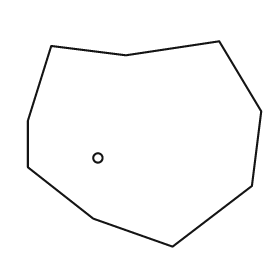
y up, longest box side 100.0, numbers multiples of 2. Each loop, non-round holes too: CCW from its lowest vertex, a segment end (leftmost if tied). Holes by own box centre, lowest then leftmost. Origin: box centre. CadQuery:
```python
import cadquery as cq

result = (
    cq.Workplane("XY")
    .moveTo(12.0, -44.0)
    .lineTo(46.0, -18.0)
    .lineTo(50.0, 14.0)
    .lineTo(32.0, 44.0)
    .lineTo(-8.0, 38.0)
    .lineTo(-40.0, 42.0)
    .lineTo(-50.0, 10.0)
    .lineTo(-50.0, -10.0)
    .lineTo(-22.0, -32.0)
    .close()
    .moveTo(-20.0, -6.0)
    .circle(2.0)
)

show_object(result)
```